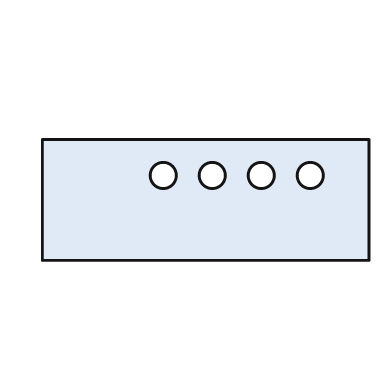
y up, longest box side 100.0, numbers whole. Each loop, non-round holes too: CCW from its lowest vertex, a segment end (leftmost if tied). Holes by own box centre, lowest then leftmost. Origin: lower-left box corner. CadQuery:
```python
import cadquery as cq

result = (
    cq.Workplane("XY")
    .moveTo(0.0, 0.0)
    .lineTo(100.0, 0.0)
    .lineTo(100.0, 37.0)
    .lineTo(0.0, 37.0)
    .close()
    .moveTo(37.0, 26.0)
    .circle(4.0)
    .moveTo(52.0, 26.0)
    .circle(4.0)
    .moveTo(67.0, 26.0)
    .circle(4.0)
    .moveTo(82.0, 26.0)
    .circle(4.0)
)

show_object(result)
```